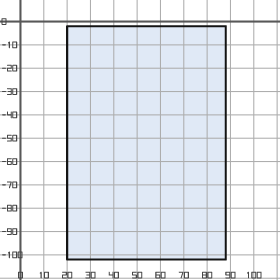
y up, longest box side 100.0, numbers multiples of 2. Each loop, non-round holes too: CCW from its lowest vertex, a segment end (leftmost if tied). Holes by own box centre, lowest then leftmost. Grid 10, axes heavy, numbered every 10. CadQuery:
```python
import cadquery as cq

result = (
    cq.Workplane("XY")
    .moveTo(20.0, -102.0)
    .lineTo(88.0, -102.0)
    .lineTo(88.0, -2.0)
    .lineTo(20.0, -2.0)
    .close()
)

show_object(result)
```